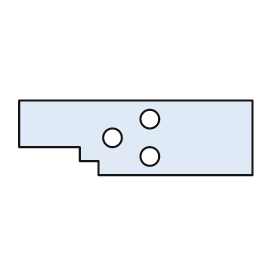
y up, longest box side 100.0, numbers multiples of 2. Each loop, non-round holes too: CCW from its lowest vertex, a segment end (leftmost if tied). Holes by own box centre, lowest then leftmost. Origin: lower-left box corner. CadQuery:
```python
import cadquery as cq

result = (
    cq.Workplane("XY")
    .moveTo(34.0, 0.0)
    .lineTo(100.0, 0.0)
    .lineTo(100.0, 32.0)
    .lineTo(0.0, 32.0)
    .lineTo(0.0, 12.0)
    .lineTo(26.0, 12.0)
    .lineTo(26.0, 6.0)
    .lineTo(34.0, 6.0)
    .close()
    .moveTo(56.0, 8.0)
    .circle(4.0)
    .moveTo(40.0, 16.0)
    .circle(4.0)
    .moveTo(56.0, 24.0)
    .circle(4.0)
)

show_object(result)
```